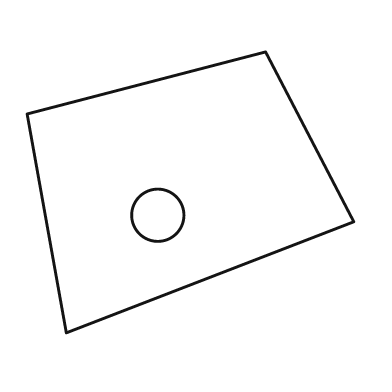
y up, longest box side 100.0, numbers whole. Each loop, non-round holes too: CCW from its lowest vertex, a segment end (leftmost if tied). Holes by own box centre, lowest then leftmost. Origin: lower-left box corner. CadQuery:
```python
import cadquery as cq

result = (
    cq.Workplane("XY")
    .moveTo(12.0, 0.0)
    .lineTo(100.0, 34.0)
    .lineTo(73.0, 86.0)
    .lineTo(0.0, 67.0)
    .close()
    .moveTo(40.0, 36.0)
    .circle(8.0)
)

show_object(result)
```